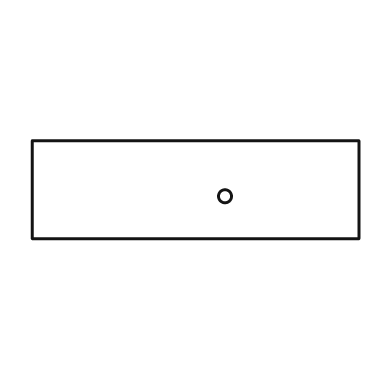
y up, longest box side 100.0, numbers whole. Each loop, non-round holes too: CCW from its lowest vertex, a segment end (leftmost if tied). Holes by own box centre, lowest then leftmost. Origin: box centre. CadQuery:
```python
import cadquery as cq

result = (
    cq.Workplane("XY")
    .moveTo(-50.0, -15.0)
    .lineTo(50.0, -15.0)
    .lineTo(50.0, 15.0)
    .lineTo(-50.0, 15.0)
    .close()
    .moveTo(9.0, -2.0)
    .circle(2.0)
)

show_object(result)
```